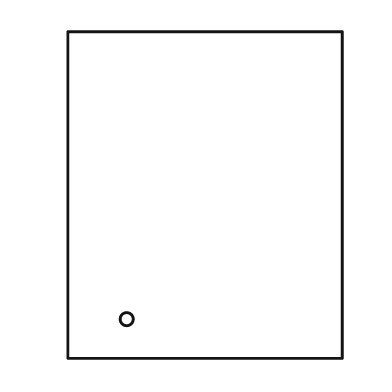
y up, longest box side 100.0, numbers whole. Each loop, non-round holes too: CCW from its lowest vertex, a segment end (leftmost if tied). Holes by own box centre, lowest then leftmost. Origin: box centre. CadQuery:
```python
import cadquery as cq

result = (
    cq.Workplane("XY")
    .moveTo(-42.0, -50.0)
    .lineTo(42.0, -50.0)
    .lineTo(42.0, 50.0)
    .lineTo(-42.0, 50.0)
    .close()
    .moveTo(-24.0, -38.0)
    .circle(2.0)
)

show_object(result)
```